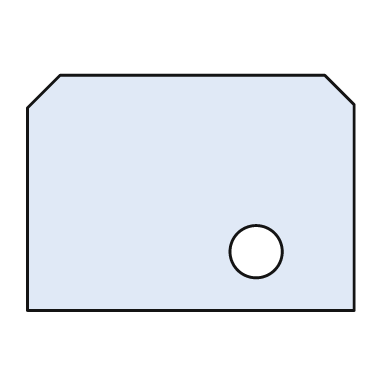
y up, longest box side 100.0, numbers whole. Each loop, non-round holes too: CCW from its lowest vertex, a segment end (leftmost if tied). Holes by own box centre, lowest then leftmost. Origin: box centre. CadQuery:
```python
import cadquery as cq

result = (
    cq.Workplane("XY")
    .moveTo(-50.0, -36.0)
    .lineTo(50.0, -36.0)
    .lineTo(50.0, 27.0)
    .lineTo(41.0, 36.0)
    .lineTo(-40.0, 36.0)
    .lineTo(-50.0, 26.0)
    .close()
    .moveTo(20.0, -18.0)
    .circle(8.0)
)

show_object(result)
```